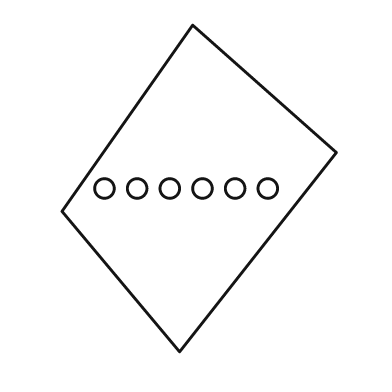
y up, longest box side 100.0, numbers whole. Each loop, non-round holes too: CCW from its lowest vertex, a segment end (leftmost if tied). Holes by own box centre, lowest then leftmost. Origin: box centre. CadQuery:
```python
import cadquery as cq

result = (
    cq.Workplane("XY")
    .moveTo(-6.0, -50.0)
    .lineTo(42.0, 11.0)
    .lineTo(-2.0, 50.0)
    .lineTo(-42.0, -7.0)
    .close()
    .moveTo(-29.0, 0.0)
    .circle(3.0)
    .moveTo(-19.0, 0.0)
    .circle(3.0)
    .moveTo(-9.0, 0.0)
    .circle(3.0)
    .moveTo(1.0, 0.0)
    .circle(3.0)
    .moveTo(11.0, 0.0)
    .circle(3.0)
    .moveTo(21.0, 0.0)
    .circle(3.0)
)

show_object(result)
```